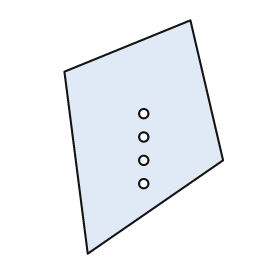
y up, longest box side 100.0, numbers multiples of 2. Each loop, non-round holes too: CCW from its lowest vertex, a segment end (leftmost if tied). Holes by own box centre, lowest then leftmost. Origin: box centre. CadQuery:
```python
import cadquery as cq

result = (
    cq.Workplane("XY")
    .moveTo(-24.0, -50.0)
    .lineTo(34.0, -10.0)
    .lineTo(20.0, 50.0)
    .lineTo(-34.0, 28.0)
    .close()
    .moveTo(0.0, -20.0)
    .circle(2.0)
    .moveTo(0.0, -10.0)
    .circle(2.0)
    .moveTo(0.0, 0.0)
    .circle(2.0)
    .moveTo(0.0, 10.0)
    .circle(2.0)
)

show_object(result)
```